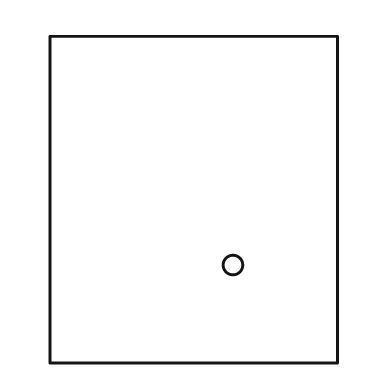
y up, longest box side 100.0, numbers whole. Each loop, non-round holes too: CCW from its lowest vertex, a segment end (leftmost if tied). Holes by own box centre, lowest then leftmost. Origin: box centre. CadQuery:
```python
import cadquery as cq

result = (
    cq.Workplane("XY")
    .moveTo(-44.0, -50.0)
    .lineTo(44.0, -50.0)
    .lineTo(44.0, 50.0)
    .lineTo(-44.0, 50.0)
    .close()
    .moveTo(12.0, -20.0)
    .circle(3.0)
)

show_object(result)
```